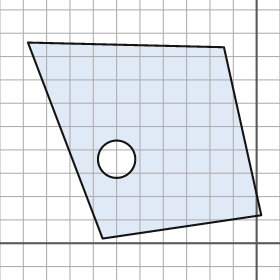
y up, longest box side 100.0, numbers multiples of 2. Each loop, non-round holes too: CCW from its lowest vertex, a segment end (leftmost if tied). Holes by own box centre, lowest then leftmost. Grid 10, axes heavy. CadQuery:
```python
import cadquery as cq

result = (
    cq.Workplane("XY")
    .moveTo(-66.0, 2.0)
    .lineTo(2.0, 12.0)
    .lineTo(-14.0, 84.0)
    .lineTo(-98.0, 86.0)
    .close()
    .moveTo(-60.0, 36.0)
    .circle(8.0)
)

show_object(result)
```